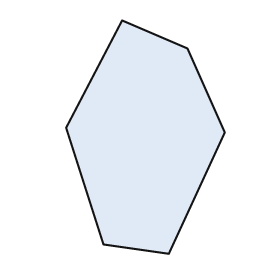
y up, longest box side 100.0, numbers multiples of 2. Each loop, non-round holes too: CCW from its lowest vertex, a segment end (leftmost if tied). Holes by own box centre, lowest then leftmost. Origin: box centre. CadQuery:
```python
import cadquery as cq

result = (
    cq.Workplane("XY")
    .moveTo(10.0, -50.0)
    .lineTo(34.0, 2.0)
    .lineTo(18.0, 38.0)
    .lineTo(-10.0, 50.0)
    .lineTo(-34.0, 4.0)
    .lineTo(-18.0, -46.0)
    .close()
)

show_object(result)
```